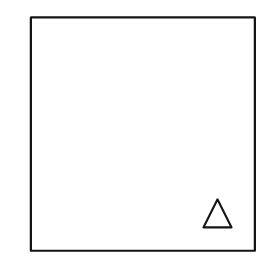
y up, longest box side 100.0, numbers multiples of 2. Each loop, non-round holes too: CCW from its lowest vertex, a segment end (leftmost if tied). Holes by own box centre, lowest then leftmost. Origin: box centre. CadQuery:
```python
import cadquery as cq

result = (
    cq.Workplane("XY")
    .moveTo(-48.0, -50.0)
    .lineTo(48.0, -50.0)
    .lineTo(48.0, 50.0)
    .lineTo(-48.0, 50.0)
    .close()
    .moveTo(26.0, -40.0)
    .lineTo(38.0, -40.0)
    .lineTo(32.0, -28.0)
    .close()
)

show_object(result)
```